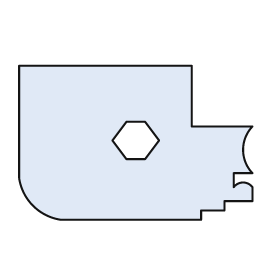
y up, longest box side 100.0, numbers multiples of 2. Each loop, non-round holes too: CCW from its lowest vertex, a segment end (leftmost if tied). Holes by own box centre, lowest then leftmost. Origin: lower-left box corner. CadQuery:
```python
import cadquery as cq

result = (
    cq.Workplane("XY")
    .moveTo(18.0, 0.0)
    .lineTo(78.0, 0.0)
    .lineTo(78.0, 4.0)
    .lineTo(88.0, 4.0)
    .lineTo(88.0, 8.0)
    .lineTo(100.0, 8.0)
    .lineTo(100.0, 14.0)
    .threePointArc((96.0, 16.0), (92.0, 14.0))
    .lineTo(92.0, 20.0)
    .lineTo(100.0, 20.0)
    .threePointArc((96.0, 30.0), (100.0, 40.0))
    .lineTo(74.0, 40.0)
    .lineTo(74.0, 66.0)
    .lineTo(0.0, 66.0)
    .lineTo(0.0, 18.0)
    .threePointArc((6.0, 6.0), (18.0, 0.0))
    .close()
    .moveTo(46.0, 26.0)
    .lineTo(54.0, 26.0)
    .lineTo(60.0, 34.0)
    .lineTo(54.0, 42.0)
    .lineTo(46.0, 42.0)
    .lineTo(40.0, 34.0)
    .close()
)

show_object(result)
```